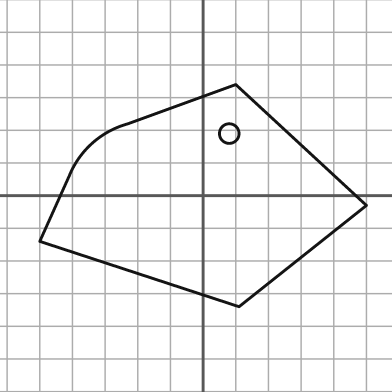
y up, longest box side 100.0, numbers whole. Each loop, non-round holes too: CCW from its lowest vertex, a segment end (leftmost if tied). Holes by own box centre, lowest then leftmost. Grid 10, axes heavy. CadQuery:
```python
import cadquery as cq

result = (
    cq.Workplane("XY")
    .moveTo(11.0, -34.0)
    .lineTo(50.0, -3.0)
    .lineTo(10.0, 34.0)
    .lineTo(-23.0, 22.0)
    .threePointArc((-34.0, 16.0), (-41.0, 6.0))
    .lineTo(-50.0, -14.0)
    .close()
    .moveTo(8.0, 19.0)
    .circle(3.0)
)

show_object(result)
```